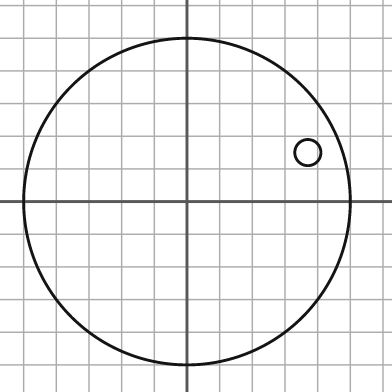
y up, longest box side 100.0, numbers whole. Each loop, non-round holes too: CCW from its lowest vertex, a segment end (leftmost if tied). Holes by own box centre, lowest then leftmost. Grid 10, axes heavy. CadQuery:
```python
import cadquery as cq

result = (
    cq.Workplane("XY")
    .moveTo(0.0, 0.0)
    .circle(50.0)
    .moveTo(37.0, 15.0)
    .circle(4.0)
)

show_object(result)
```